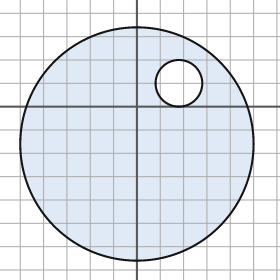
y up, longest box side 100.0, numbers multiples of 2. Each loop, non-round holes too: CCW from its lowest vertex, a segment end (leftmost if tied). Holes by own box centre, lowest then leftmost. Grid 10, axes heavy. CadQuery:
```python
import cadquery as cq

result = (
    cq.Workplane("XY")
    .moveTo(0.0, -16.0)
    .circle(50.0)
    .moveTo(18.0, 10.0)
    .circle(10.0)
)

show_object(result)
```